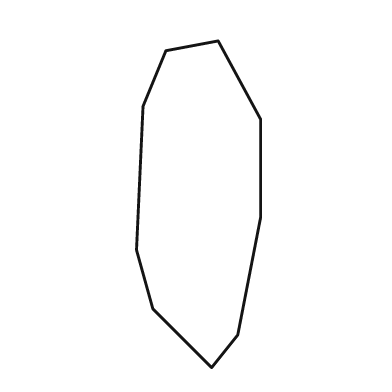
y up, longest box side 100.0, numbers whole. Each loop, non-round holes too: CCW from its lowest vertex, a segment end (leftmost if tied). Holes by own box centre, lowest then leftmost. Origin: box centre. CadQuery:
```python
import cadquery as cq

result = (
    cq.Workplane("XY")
    .moveTo(4.0, -50.0)
    .lineTo(12.0, -40.0)
    .lineTo(19.0, -4.0)
    .lineTo(19.0, 26.0)
    .lineTo(6.0, 50.0)
    .lineTo(-10.0, 47.0)
    .lineTo(-17.0, 30.0)
    .lineTo(-19.0, -14.0)
    .lineTo(-14.0, -32.0)
    .close()
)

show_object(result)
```